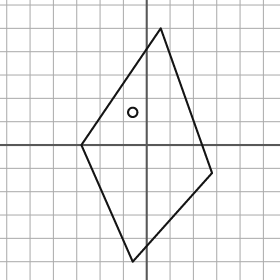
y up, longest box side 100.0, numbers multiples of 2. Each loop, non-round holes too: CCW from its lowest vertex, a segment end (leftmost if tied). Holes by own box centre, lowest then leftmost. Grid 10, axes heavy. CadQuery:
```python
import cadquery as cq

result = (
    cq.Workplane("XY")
    .moveTo(-6.0, -50.0)
    .lineTo(28.0, -12.0)
    .lineTo(6.0, 50.0)
    .lineTo(-28.0, 0.0)
    .close()
    .moveTo(-6.0, 14.0)
    .circle(2.0)
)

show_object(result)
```